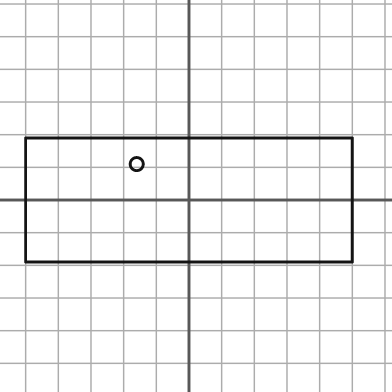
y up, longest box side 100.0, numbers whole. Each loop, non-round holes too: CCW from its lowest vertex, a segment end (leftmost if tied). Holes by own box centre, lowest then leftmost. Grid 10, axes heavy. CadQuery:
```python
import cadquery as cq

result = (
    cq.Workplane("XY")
    .moveTo(-50.0, -19.0)
    .lineTo(50.0, -19.0)
    .lineTo(50.0, 19.0)
    .lineTo(-50.0, 19.0)
    .close()
    .moveTo(-16.0, 11.0)
    .circle(2.0)
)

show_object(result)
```